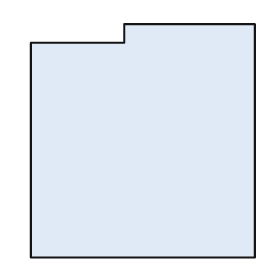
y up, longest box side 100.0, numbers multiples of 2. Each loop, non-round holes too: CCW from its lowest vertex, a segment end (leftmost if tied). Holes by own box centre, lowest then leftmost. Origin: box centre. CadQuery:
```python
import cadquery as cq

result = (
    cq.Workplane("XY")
    .moveTo(-48.0, -50.0)
    .lineTo(48.0, -50.0)
    .lineTo(48.0, 50.0)
    .lineTo(-8.0, 50.0)
    .lineTo(-8.0, 42.0)
    .lineTo(-48.0, 42.0)
    .close()
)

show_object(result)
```